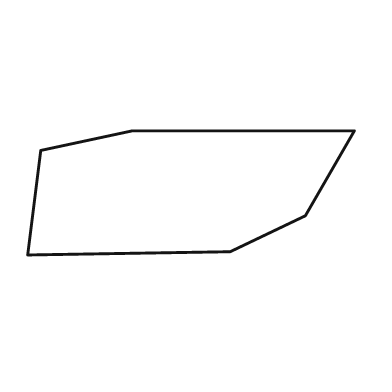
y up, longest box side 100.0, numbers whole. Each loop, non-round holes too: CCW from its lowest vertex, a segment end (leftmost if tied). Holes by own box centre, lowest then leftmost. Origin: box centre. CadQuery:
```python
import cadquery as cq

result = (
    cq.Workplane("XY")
    .moveTo(-50.0, -19.0)
    .lineTo(12.0, -18.0)
    .lineTo(35.0, -7.0)
    .lineTo(50.0, 19.0)
    .lineTo(-18.0, 19.0)
    .lineTo(-46.0, 13.0)
    .close()
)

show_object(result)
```